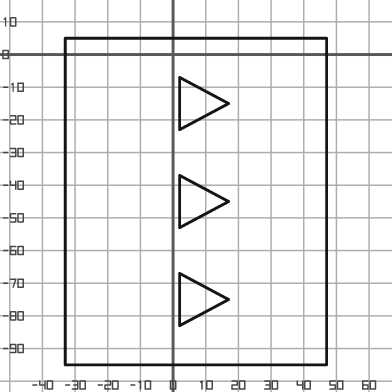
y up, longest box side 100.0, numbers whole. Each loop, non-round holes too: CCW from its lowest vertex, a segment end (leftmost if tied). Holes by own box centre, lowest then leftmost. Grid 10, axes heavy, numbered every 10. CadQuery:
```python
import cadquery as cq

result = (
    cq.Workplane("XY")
    .moveTo(-33.0, -95.0)
    .lineTo(47.0, -95.0)
    .lineTo(47.0, 5.0)
    .lineTo(-33.0, 5.0)
    .close()
    .moveTo(2.0, -83.0)
    .lineTo(17.0, -75.0)
    .lineTo(2.0, -67.0)
    .close()
    .moveTo(2.0, -53.0)
    .lineTo(17.0, -45.0)
    .lineTo(2.0, -37.0)
    .close()
    .moveTo(2.0, -23.0)
    .lineTo(17.0, -15.0)
    .lineTo(2.0, -7.0)
    .close()
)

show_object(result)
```